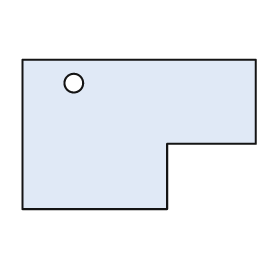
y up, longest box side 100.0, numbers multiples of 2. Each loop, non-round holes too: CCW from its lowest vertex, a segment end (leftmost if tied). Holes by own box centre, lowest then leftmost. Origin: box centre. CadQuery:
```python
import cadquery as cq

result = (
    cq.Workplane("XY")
    .moveTo(-50.0, -32.0)
    .lineTo(12.0, -32.0)
    .lineTo(12.0, -4.0)
    .lineTo(50.0, -4.0)
    .lineTo(50.0, 32.0)
    .lineTo(-50.0, 32.0)
    .close()
    .moveTo(-28.0, 22.0)
    .circle(4.0)
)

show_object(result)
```